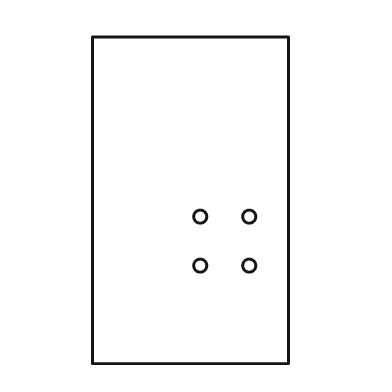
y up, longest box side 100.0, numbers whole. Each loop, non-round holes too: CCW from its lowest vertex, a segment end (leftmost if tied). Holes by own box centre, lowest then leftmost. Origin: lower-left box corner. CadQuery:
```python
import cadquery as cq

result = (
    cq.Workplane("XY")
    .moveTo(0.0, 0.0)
    .lineTo(60.0, 0.0)
    .lineTo(60.0, 100.0)
    .lineTo(0.0, 100.0)
    .close()
    .moveTo(33.0, 30.0)
    .circle(2.0)
    .moveTo(48.0, 30.0)
    .circle(2.0)
    .moveTo(33.0, 45.0)
    .circle(2.0)
    .moveTo(48.0, 45.0)
    .circle(2.0)
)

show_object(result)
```